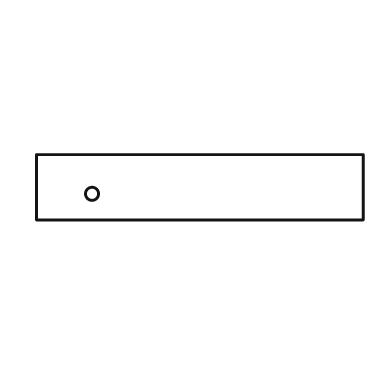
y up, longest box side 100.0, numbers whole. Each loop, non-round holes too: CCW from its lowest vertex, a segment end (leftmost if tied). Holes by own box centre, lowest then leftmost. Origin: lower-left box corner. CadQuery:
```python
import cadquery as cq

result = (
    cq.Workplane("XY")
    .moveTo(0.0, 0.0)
    .lineTo(100.0, 0.0)
    .lineTo(100.0, 20.0)
    .lineTo(0.0, 20.0)
    .close()
    .moveTo(17.0, 8.0)
    .circle(2.0)
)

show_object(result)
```